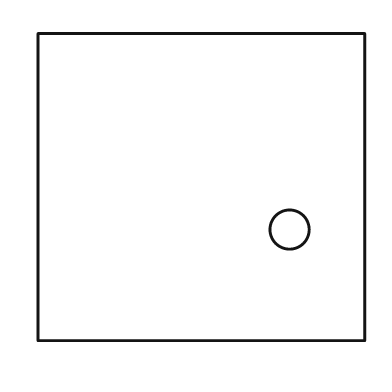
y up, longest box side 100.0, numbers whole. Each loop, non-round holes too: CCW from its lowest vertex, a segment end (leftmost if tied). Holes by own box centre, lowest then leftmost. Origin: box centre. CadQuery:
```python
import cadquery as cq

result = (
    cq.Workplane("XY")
    .moveTo(-50.0, -47.0)
    .lineTo(50.0, -47.0)
    .lineTo(50.0, 47.0)
    .lineTo(-50.0, 47.0)
    .close()
    .moveTo(27.0, -13.0)
    .circle(6.0)
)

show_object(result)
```